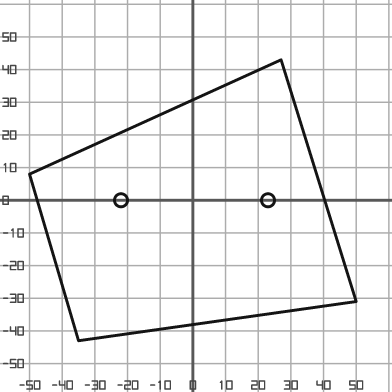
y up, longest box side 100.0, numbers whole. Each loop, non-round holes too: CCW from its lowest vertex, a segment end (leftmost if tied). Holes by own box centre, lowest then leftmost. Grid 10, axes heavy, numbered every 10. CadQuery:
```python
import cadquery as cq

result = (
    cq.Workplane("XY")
    .moveTo(-35.0, -43.0)
    .lineTo(50.0, -31.0)
    .lineTo(27.0, 43.0)
    .lineTo(-50.0, 8.0)
    .close()
    .moveTo(-22.0, 0.0)
    .circle(2.0)
    .moveTo(23.0, 0.0)
    .circle(2.0)
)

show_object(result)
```